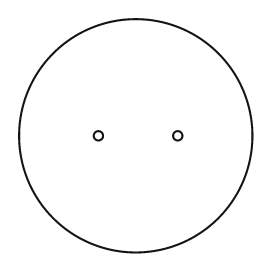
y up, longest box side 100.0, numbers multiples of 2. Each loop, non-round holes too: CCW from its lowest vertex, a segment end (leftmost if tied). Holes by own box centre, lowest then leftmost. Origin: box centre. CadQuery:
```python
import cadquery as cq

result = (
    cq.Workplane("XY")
    .moveTo(0.0, 0.0)
    .circle(50.0)
    .moveTo(-16.0, 0.0)
    .circle(2.0)
    .moveTo(18.0, 0.0)
    .circle(2.0)
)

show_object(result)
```